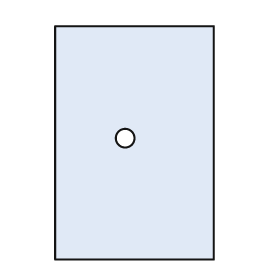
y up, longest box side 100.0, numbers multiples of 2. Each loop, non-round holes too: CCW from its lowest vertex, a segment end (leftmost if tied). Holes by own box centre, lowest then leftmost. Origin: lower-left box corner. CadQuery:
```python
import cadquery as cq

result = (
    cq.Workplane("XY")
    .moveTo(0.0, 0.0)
    .lineTo(68.0, 0.0)
    .lineTo(68.0, 100.0)
    .lineTo(0.0, 100.0)
    .close()
    .moveTo(30.0, 52.0)
    .circle(4.0)
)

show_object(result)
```